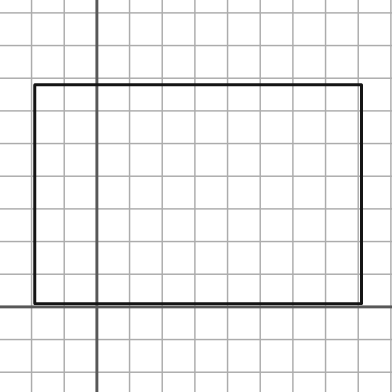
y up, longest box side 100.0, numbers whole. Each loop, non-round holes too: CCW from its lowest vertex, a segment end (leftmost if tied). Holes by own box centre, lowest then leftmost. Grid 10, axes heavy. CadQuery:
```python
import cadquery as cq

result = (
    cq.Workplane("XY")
    .moveTo(-19.0, 1.0)
    .lineTo(81.0, 1.0)
    .lineTo(81.0, 68.0)
    .lineTo(-19.0, 68.0)
    .close()
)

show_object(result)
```